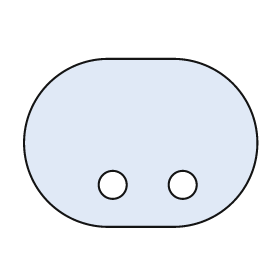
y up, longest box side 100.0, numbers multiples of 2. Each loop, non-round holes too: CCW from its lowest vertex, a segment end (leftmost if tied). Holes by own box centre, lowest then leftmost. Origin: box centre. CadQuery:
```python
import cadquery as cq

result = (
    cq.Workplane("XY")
    .moveTo(-14.0, -36.0)
    .lineTo(14.0, -36.0)
    .threePointArc((50.0, 0.0), (14.0, 36.0))
    .lineTo(-14.0, 36.0)
    .threePointArc((-50.0, 0.0), (-14.0, -36.0))
    .close()
    .moveTo(-12.0, -18.0)
    .circle(6.0)
    .moveTo(18.0, -18.0)
    .circle(6.0)
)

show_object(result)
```